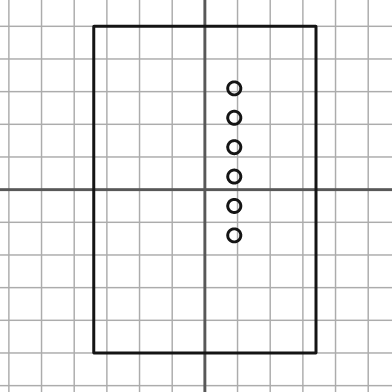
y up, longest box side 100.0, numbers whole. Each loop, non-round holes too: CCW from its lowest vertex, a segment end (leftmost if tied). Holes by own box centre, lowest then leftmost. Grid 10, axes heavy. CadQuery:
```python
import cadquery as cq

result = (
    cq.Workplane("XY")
    .moveTo(-34.0, -50.0)
    .lineTo(34.0, -50.0)
    .lineTo(34.0, 50.0)
    .lineTo(-34.0, 50.0)
    .close()
    .moveTo(9.0, -14.0)
    .circle(2.0)
    .moveTo(9.0, -5.0)
    .circle(2.0)
    .moveTo(9.0, 4.0)
    .circle(2.0)
    .moveTo(9.0, 13.0)
    .circle(2.0)
    .moveTo(9.0, 22.0)
    .circle(2.0)
    .moveTo(9.0, 31.0)
    .circle(2.0)
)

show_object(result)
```